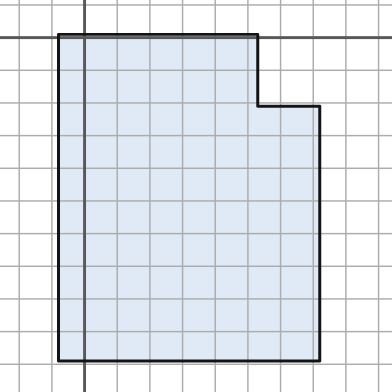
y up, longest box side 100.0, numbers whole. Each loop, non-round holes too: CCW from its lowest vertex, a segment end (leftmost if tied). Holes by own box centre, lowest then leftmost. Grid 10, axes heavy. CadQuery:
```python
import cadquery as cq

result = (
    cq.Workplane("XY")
    .moveTo(-8.0, -99.0)
    .lineTo(72.0, -99.0)
    .lineTo(72.0, -21.0)
    .lineTo(53.0, -21.0)
    .lineTo(53.0, 1.0)
    .lineTo(-8.0, 1.0)
    .close()
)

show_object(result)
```